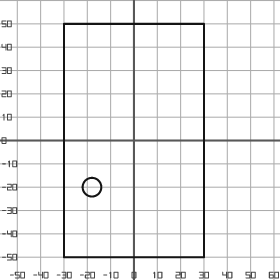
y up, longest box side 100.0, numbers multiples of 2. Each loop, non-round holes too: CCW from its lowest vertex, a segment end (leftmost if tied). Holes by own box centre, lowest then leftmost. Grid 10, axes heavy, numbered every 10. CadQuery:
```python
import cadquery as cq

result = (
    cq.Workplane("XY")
    .moveTo(-30.0, -50.0)
    .lineTo(30.0, -50.0)
    .lineTo(30.0, 50.0)
    .lineTo(-30.0, 50.0)
    .close()
    .moveTo(-18.0, -20.0)
    .circle(4.0)
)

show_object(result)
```